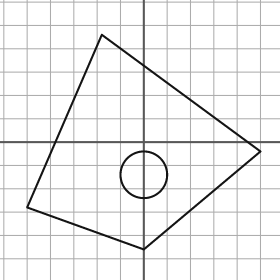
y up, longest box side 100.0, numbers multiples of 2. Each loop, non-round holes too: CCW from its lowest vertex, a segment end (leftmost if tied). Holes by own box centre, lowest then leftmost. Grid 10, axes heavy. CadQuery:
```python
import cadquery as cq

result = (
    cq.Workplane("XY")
    .moveTo(0.0, -46.0)
    .lineTo(50.0, -4.0)
    .lineTo(-18.0, 46.0)
    .lineTo(-50.0, -28.0)
    .close()
    .moveTo(0.0, -14.0)
    .circle(10.0)
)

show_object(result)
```